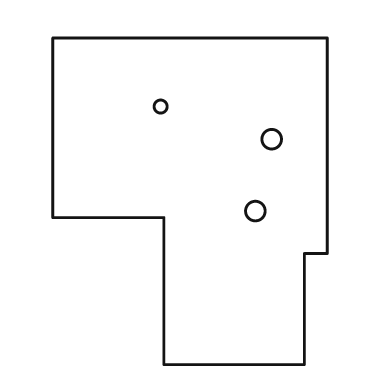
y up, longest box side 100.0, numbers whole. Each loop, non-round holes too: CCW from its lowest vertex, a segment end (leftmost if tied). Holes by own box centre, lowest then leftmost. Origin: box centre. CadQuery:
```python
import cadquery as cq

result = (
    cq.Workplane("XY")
    .moveTo(-8.0, -50.0)
    .lineTo(35.0, -50.0)
    .lineTo(35.0, -16.0)
    .lineTo(42.0, -16.0)
    .lineTo(42.0, 50.0)
    .lineTo(-42.0, 50.0)
    .lineTo(-42.0, -5.0)
    .lineTo(-8.0, -5.0)
    .close()
    .moveTo(20.0, -3.0)
    .circle(3.0)
    .moveTo(25.0, 19.0)
    .circle(3.0)
    .moveTo(-9.0, 29.0)
    .circle(2.0)
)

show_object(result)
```